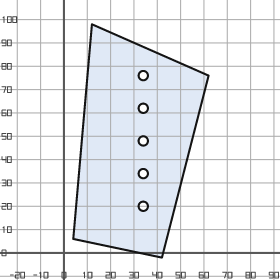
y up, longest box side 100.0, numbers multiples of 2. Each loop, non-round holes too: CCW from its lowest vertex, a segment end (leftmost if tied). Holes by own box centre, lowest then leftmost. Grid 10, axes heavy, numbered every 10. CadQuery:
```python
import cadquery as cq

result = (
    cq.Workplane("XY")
    .moveTo(42.0, -2.0)
    .lineTo(62.0, 76.0)
    .lineTo(12.0, 98.0)
    .lineTo(4.0, 6.0)
    .close()
    .moveTo(34.0, 20.0)
    .circle(2.0)
    .moveTo(34.0, 34.0)
    .circle(2.0)
    .moveTo(34.0, 48.0)
    .circle(2.0)
    .moveTo(34.0, 62.0)
    .circle(2.0)
    .moveTo(34.0, 76.0)
    .circle(2.0)
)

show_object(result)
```